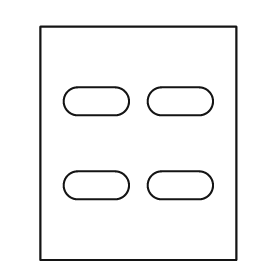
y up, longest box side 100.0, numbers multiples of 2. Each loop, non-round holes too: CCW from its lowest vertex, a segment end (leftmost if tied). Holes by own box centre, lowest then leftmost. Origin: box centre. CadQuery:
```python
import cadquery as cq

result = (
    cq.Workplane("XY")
    .moveTo(-42.0, -50.0)
    .lineTo(42.0, -50.0)
    .lineTo(42.0, 50.0)
    .lineTo(-42.0, 50.0)
    .close()
    .moveTo(-26.0, -24.0)
    .lineTo(-10.0, -24.0)
    .threePointArc((-4.0, -18.0), (-10.0, -12.0))
    .lineTo(-26.0, -12.0)
    .threePointArc((-32.0, -18.0), (-26.0, -24.0))
    .close()
    .moveTo(10.0, -24.0)
    .lineTo(26.0, -24.0)
    .threePointArc((32.0, -18.0), (26.0, -12.0))
    .lineTo(10.0, -12.0)
    .threePointArc((4.0, -18.0), (10.0, -24.0))
    .close()
    .moveTo(-26.0, 12.0)
    .lineTo(-10.0, 12.0)
    .threePointArc((-4.0, 18.0), (-10.0, 24.0))
    .lineTo(-26.0, 24.0)
    .threePointArc((-32.0, 18.0), (-26.0, 12.0))
    .close()
    .moveTo(10.0, 12.0)
    .lineTo(26.0, 12.0)
    .threePointArc((32.0, 18.0), (26.0, 24.0))
    .lineTo(10.0, 24.0)
    .threePointArc((4.0, 18.0), (10.0, 12.0))
    .close()
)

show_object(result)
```